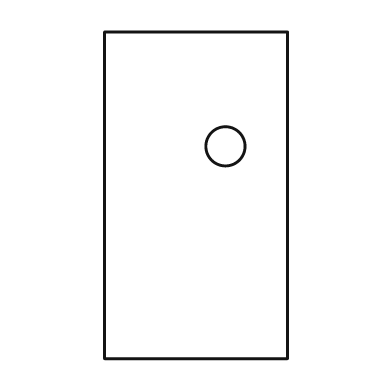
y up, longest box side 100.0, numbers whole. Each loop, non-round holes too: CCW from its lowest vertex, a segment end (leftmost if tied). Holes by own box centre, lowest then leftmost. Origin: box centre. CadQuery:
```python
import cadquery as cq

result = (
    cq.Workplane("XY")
    .moveTo(-28.0, -50.0)
    .lineTo(28.0, -50.0)
    .lineTo(28.0, 50.0)
    .lineTo(-28.0, 50.0)
    .close()
    .moveTo(9.0, 15.0)
    .circle(6.0)
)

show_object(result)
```